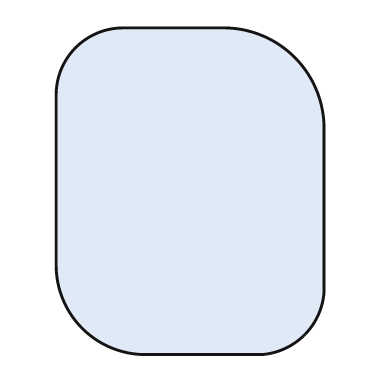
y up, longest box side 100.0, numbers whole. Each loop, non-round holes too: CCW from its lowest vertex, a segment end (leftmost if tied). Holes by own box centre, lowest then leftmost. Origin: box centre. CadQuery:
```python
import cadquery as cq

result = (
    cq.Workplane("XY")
    .moveTo(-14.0, -50.0)
    .lineTo(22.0, -50.0)
    .threePointArc((35.0, -44.0), (41.0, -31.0))
    .lineTo(41.0, 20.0)
    .threePointArc((32.0, 41.0), (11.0, 50.0))
    .lineTo(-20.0, 50.0)
    .threePointArc((-35.0, 44.0), (-41.0, 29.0))
    .lineTo(-41.0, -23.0)
    .threePointArc((-33.0, -42.0), (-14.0, -50.0))
    .close()
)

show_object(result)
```